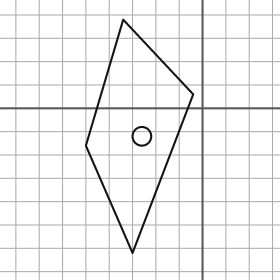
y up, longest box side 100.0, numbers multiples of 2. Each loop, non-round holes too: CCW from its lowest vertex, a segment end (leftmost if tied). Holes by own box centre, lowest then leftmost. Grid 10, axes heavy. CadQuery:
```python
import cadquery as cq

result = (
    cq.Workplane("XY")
    .moveTo(-30.0, -62.0)
    .lineTo(-4.0, 6.0)
    .lineTo(-34.0, 38.0)
    .lineTo(-50.0, -16.0)
    .close()
    .moveTo(-26.0, -12.0)
    .circle(4.0)
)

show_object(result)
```